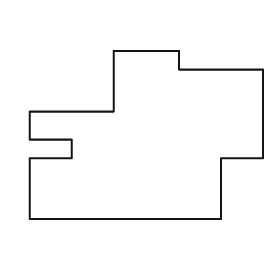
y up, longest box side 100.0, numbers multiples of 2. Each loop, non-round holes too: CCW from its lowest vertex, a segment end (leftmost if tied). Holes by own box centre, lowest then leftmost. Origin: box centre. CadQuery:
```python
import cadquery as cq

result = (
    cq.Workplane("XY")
    .moveTo(-50.0, -36.0)
    .lineTo(32.0, -36.0)
    .lineTo(32.0, -10.0)
    .lineTo(50.0, -10.0)
    .lineTo(50.0, 28.0)
    .lineTo(14.0, 28.0)
    .lineTo(14.0, 36.0)
    .lineTo(-14.0, 36.0)
    .lineTo(-14.0, 10.0)
    .lineTo(-50.0, 10.0)
    .lineTo(-50.0, -2.0)
    .lineTo(-32.0, -2.0)
    .lineTo(-32.0, -10.0)
    .lineTo(-50.0, -10.0)
    .close()
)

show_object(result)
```